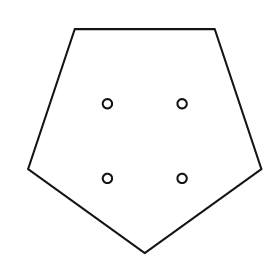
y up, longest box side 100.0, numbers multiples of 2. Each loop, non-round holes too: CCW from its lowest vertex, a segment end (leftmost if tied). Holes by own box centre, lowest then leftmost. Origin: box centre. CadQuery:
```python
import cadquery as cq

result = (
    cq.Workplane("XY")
    .moveTo(0.0, -48.0)
    .lineTo(50.0, -12.0)
    .lineTo(30.0, 48.0)
    .lineTo(-30.0, 48.0)
    .lineTo(-50.0, -12.0)
    .close()
    .moveTo(-16.0, -16.0)
    .circle(2.0)
    .moveTo(16.0, -16.0)
    .circle(2.0)
    .moveTo(-16.0, 16.0)
    .circle(2.0)
    .moveTo(16.0, 16.0)
    .circle(2.0)
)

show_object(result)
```